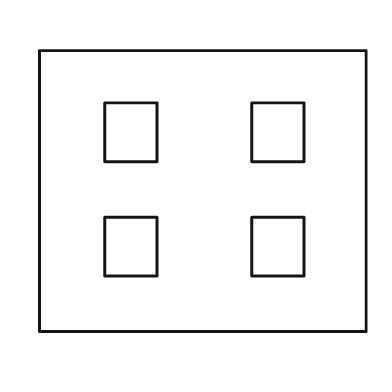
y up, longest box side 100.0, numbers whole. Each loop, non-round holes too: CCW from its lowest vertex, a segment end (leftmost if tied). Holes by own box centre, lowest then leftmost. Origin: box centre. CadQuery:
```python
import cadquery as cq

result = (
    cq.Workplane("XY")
    .moveTo(-50.0, -43.0)
    .lineTo(50.0, -43.0)
    .lineTo(50.0, 43.0)
    .lineTo(-50.0, 43.0)
    .close()
    .moveTo(-30.0, -26.0)
    .lineTo(-14.0, -26.0)
    .lineTo(-14.0, -8.0)
    .lineTo(-30.0, -8.0)
    .close()
    .moveTo(15.0, -26.0)
    .lineTo(31.0, -26.0)
    .lineTo(31.0, -8.0)
    .lineTo(15.0, -8.0)
    .close()
    .moveTo(-30.0, 9.0)
    .lineTo(-14.0, 9.0)
    .lineTo(-14.0, 27.0)
    .lineTo(-30.0, 27.0)
    .close()
    .moveTo(15.0, 9.0)
    .lineTo(31.0, 9.0)
    .lineTo(31.0, 27.0)
    .lineTo(15.0, 27.0)
    .close()
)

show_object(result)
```